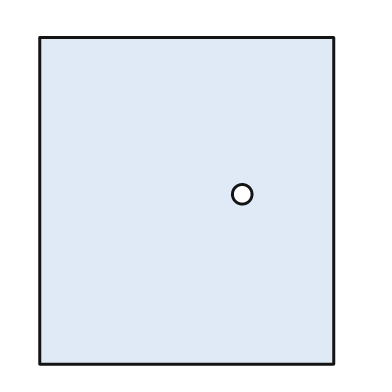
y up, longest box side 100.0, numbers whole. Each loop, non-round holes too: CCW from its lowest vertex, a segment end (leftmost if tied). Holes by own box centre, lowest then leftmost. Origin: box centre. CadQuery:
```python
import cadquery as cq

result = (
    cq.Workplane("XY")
    .moveTo(-45.0, -50.0)
    .lineTo(45.0, -50.0)
    .lineTo(45.0, 50.0)
    .lineTo(-45.0, 50.0)
    .close()
    .moveTo(17.0, 2.0)
    .circle(3.0)
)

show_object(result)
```